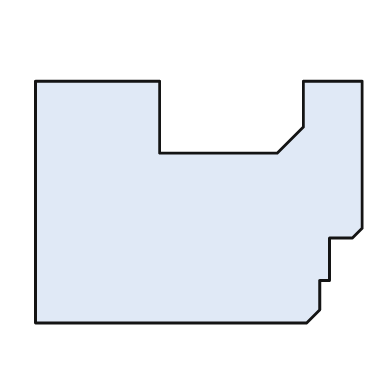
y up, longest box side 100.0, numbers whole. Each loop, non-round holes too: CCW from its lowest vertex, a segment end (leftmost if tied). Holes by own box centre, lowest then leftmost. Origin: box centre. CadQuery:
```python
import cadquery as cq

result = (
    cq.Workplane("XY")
    .moveTo(-50.0, -37.0)
    .lineTo(33.0, -37.0)
    .lineTo(37.0, -33.0)
    .lineTo(37.0, -24.0)
    .lineTo(40.0, -24.0)
    .lineTo(40.0, -11.0)
    .lineTo(47.0, -11.0)
    .lineTo(50.0, -8.0)
    .lineTo(50.0, 37.0)
    .lineTo(32.0, 37.0)
    .lineTo(32.0, 23.0)
    .lineTo(24.0, 15.0)
    .lineTo(-12.0, 15.0)
    .lineTo(-12.0, 37.0)
    .lineTo(-50.0, 37.0)
    .close()
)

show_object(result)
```